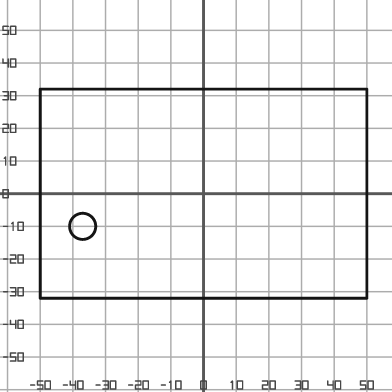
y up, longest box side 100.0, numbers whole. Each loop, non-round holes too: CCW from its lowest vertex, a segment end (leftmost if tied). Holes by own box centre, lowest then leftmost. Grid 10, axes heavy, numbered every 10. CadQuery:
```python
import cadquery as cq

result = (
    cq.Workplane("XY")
    .moveTo(-50.0, -32.0)
    .lineTo(50.0, -32.0)
    .lineTo(50.0, 32.0)
    .lineTo(-50.0, 32.0)
    .close()
    .moveTo(-37.0, -10.0)
    .circle(4.0)
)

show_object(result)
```